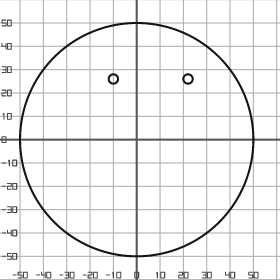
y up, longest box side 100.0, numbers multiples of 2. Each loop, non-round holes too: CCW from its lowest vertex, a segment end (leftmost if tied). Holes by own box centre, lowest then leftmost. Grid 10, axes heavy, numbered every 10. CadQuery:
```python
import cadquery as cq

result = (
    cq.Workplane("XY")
    .moveTo(0.0, 0.0)
    .circle(50.0)
    .moveTo(-10.0, 26.0)
    .circle(2.0)
    .moveTo(22.0, 26.0)
    .circle(2.0)
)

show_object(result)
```